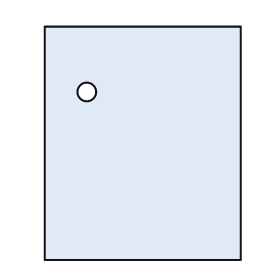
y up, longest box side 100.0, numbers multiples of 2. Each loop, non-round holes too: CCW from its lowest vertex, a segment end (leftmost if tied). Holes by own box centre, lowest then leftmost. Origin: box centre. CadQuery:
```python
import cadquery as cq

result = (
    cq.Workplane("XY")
    .moveTo(-42.0, -50.0)
    .lineTo(42.0, -50.0)
    .lineTo(42.0, 50.0)
    .lineTo(-42.0, 50.0)
    .close()
    .moveTo(-24.0, 22.0)
    .circle(4.0)
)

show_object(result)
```